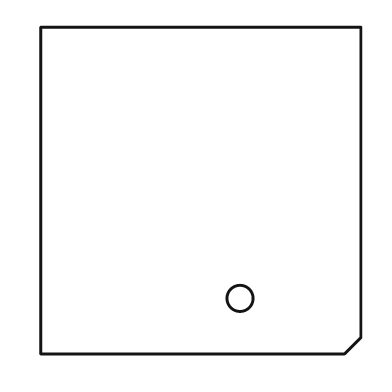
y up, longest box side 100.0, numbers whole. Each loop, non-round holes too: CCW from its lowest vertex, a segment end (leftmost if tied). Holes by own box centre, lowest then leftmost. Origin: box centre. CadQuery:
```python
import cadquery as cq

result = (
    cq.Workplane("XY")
    .moveTo(-49.0, -50.0)
    .lineTo(44.0, -50.0)
    .lineTo(49.0, -45.0)
    .lineTo(49.0, 50.0)
    .lineTo(-49.0, 50.0)
    .close()
    .moveTo(12.0, -33.0)
    .circle(4.0)
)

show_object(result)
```